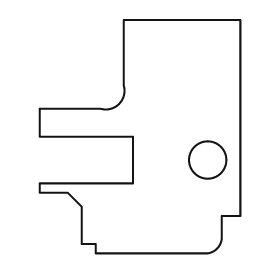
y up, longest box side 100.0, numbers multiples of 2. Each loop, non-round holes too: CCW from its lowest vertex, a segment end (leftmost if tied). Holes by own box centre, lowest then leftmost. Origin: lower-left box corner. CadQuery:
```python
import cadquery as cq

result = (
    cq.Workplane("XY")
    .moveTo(24.0, 0.0)
    .lineTo(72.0, 0.0)
    .threePointArc((76.0, 2.0), (78.0, 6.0))
    .lineTo(78.0, 16.0)
    .lineTo(86.0, 16.0)
    .lineTo(86.0, 100.0)
    .lineTo(36.0, 100.0)
    .lineTo(36.0, 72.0)
    .threePointArc((34.0, 64.0), (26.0, 62.0))
    .lineTo(0.0, 62.0)
    .lineTo(0.0, 50.0)
    .lineTo(40.0, 50.0)
    .lineTo(40.0, 30.0)
    .lineTo(0.0, 30.0)
    .lineTo(0.0, 26.0)
    .lineTo(12.0, 26.0)
    .lineTo(18.0, 20.0)
    .lineTo(18.0, 4.0)
    .lineTo(24.0, 4.0)
    .close()
    .moveTo(72.0, 40.0)
    .circle(8.0)
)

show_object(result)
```